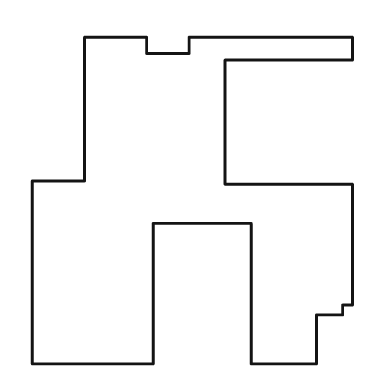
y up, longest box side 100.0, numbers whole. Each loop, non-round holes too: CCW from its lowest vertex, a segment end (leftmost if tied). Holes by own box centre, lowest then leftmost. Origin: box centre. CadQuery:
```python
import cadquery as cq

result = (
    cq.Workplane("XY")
    .moveTo(-49.0, -50.0)
    .lineTo(-12.0, -50.0)
    .lineTo(-12.0, -7.0)
    .lineTo(18.0, -7.0)
    .lineTo(18.0, -50.0)
    .lineTo(38.0, -50.0)
    .lineTo(38.0, -35.0)
    .lineTo(46.0, -35.0)
    .lineTo(46.0, -32.0)
    .lineTo(49.0, -32.0)
    .lineTo(49.0, 5.0)
    .lineTo(10.0, 5.0)
    .lineTo(10.0, 43.0)
    .lineTo(49.0, 43.0)
    .lineTo(49.0, 50.0)
    .lineTo(-1.0, 50.0)
    .lineTo(-1.0, 45.0)
    .lineTo(-14.0, 45.0)
    .lineTo(-14.0, 50.0)
    .lineTo(-33.0, 50.0)
    .lineTo(-33.0, 6.0)
    .lineTo(-49.0, 6.0)
    .close()
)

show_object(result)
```